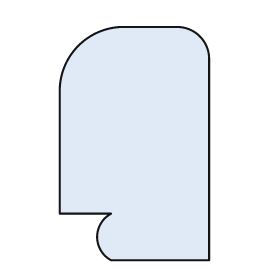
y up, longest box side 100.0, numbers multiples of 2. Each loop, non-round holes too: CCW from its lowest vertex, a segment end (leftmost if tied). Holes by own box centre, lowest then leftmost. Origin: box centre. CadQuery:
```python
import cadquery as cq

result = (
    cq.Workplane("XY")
    .moveTo(-10.0, -50.0)
    .lineTo(32.0, -50.0)
    .lineTo(32.0, 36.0)
    .threePointArc((28.0, 46.0), (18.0, 50.0))
    .lineTo(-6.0, 50.0)
    .threePointArc((-24.0, 42.0), (-32.0, 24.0))
    .lineTo(-32.0, -30.0)
    .lineTo(-10.0, -30.0)
    .threePointArc((-16.0, -40.0), (-10.0, -50.0))
    .close()
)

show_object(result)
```